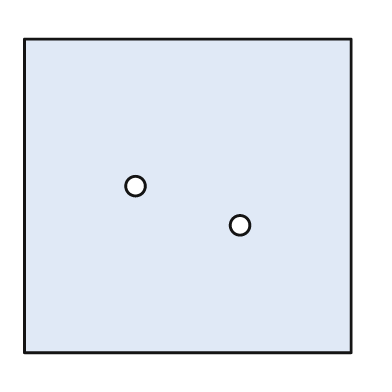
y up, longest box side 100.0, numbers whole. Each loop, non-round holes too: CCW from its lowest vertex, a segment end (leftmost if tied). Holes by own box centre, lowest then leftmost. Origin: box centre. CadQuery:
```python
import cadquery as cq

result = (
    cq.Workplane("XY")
    .moveTo(-50.0, -48.0)
    .lineTo(50.0, -48.0)
    .lineTo(50.0, 48.0)
    .lineTo(-50.0, 48.0)
    .close()
    .moveTo(16.0, -9.0)
    .circle(3.0)
    .moveTo(-16.0, 3.0)
    .circle(3.0)
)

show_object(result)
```